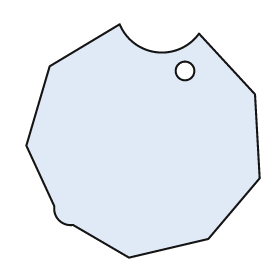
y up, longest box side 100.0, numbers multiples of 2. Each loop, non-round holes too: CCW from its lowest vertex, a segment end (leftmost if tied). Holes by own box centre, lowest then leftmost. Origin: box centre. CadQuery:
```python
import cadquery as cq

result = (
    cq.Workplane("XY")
    .moveTo(-6.0, -50.0)
    .lineTo(28.0, -42.0)
    .lineTo(50.0, -16.0)
    .lineTo(48.0, 20.0)
    .lineTo(24.0, 46.0)
    .threePointArc((6.0, 38.0), (-10.0, 50.0))
    .lineTo(-40.0, 32.0)
    .lineTo(-50.0, -2.0)
    .lineTo(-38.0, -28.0)
    .threePointArc((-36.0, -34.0), (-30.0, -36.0))
    .close()
    .moveTo(18.0, 30.0)
    .circle(4.0)
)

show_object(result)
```